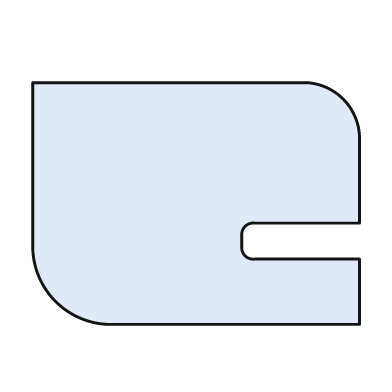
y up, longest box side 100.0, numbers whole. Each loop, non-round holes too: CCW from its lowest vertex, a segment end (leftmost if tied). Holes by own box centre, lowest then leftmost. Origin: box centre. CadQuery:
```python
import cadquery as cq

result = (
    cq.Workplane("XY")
    .moveTo(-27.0, -37.0)
    .lineTo(50.0, -37.0)
    .lineTo(50.0, -17.0)
    .lineTo(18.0, -17.0)
    .threePointArc((15.0, -16.0), (14.0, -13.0))
    .lineTo(14.0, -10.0)
    .threePointArc((15.0, -7.0), (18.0, -6.0))
    .lineTo(50.0, -6.0)
    .lineTo(50.0, 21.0)
    .threePointArc((45.0, 32.0), (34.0, 37.0))
    .lineTo(-50.0, 37.0)
    .lineTo(-50.0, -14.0)
    .threePointArc((-43.0, -30.0), (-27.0, -37.0))
    .close()
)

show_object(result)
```